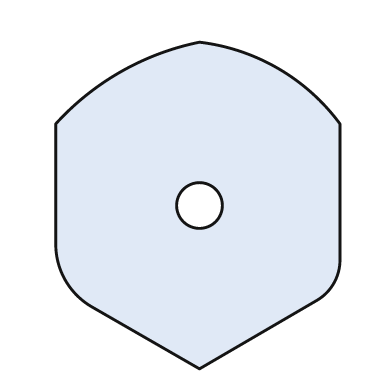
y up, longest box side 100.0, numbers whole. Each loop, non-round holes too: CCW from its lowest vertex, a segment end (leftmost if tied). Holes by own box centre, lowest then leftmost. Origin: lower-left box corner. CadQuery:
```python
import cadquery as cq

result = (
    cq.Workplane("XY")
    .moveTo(44.0, 0.0)
    .lineTo(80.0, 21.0)
    .threePointArc((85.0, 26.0), (87.0, 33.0))
    .lineTo(87.0, 75.0)
    .threePointArc((68.0, 92.0), (44.0, 100.0))
    .threePointArc((20.0, 91.0), (0.0, 75.0))
    .lineTo(0.0, 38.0)
    .threePointArc((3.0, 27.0), (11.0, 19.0))
    .close()
    .moveTo(44.0, 50.0)
    .circle(7.0)
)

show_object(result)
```